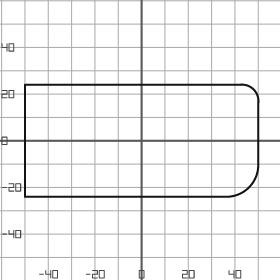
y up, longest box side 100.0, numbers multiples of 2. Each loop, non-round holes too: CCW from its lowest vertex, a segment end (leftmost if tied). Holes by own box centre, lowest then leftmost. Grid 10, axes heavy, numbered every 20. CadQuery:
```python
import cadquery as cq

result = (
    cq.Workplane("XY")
    .moveTo(-50.0, -24.0)
    .lineTo(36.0, -24.0)
    .threePointArc((46.0, -20.0), (50.0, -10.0))
    .lineTo(50.0, 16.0)
    .threePointArc((48.0, 22.0), (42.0, 24.0))
    .lineTo(-50.0, 24.0)
    .close()
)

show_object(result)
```